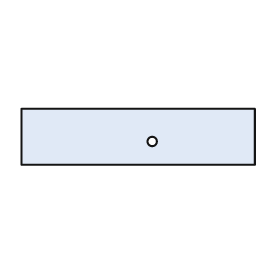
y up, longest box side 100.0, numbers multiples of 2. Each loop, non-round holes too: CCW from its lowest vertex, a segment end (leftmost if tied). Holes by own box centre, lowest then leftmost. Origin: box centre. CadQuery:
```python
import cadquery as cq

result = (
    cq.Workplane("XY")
    .moveTo(-50.0, -12.0)
    .lineTo(50.0, -12.0)
    .lineTo(50.0, 12.0)
    .lineTo(-50.0, 12.0)
    .close()
    .moveTo(6.0, -2.0)
    .circle(2.0)
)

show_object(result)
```